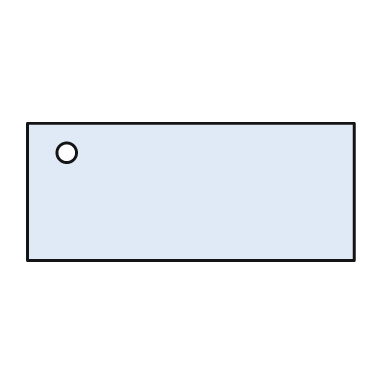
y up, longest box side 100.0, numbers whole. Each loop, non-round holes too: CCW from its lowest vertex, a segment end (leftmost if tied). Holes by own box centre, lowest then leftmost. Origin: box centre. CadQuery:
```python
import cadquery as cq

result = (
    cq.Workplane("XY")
    .moveTo(-50.0, -21.0)
    .lineTo(50.0, -21.0)
    .lineTo(50.0, 21.0)
    .lineTo(-50.0, 21.0)
    .close()
    .moveTo(-38.0, 12.0)
    .circle(3.0)
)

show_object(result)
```